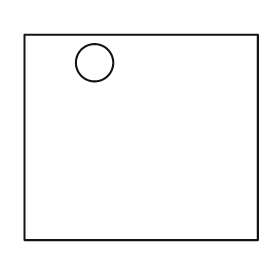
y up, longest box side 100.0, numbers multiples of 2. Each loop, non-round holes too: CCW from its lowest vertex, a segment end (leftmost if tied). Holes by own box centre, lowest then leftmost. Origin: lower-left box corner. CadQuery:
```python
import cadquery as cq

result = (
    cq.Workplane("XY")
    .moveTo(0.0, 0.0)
    .lineTo(100.0, 0.0)
    .lineTo(100.0, 88.0)
    .lineTo(0.0, 88.0)
    .close()
    .moveTo(30.0, 76.0)
    .circle(8.0)
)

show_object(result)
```